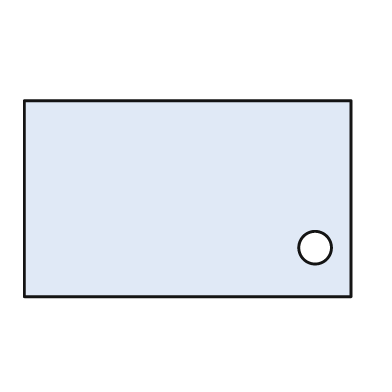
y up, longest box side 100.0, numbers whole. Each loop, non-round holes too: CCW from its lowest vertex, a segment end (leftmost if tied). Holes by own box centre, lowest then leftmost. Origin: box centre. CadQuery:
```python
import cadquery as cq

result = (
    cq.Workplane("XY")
    .moveTo(-50.0, -30.0)
    .lineTo(50.0, -30.0)
    .lineTo(50.0, 30.0)
    .lineTo(-50.0, 30.0)
    .close()
    .moveTo(39.0, -15.0)
    .circle(5.0)
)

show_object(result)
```